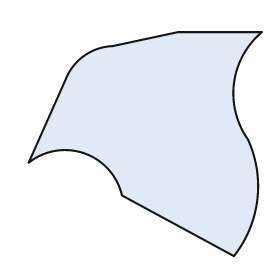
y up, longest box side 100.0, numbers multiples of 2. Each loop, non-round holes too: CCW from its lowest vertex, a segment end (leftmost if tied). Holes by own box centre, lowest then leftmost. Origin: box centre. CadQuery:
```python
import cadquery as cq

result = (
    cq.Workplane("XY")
    .moveTo(38.0, -48.0)
    .threePointArc((48.0, -24.0), (44.0, 2.0))
    .threePointArc((38.0, 26.0), (50.0, 48.0))
    .lineTo(14.0, 48.0)
    .lineTo(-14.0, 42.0)
    .threePointArc((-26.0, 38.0), (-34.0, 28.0))
    .lineTo(-50.0, -8.0)
    .threePointArc((-26.0, -4.0), (-10.0, -22.0))
    .close()
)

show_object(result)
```